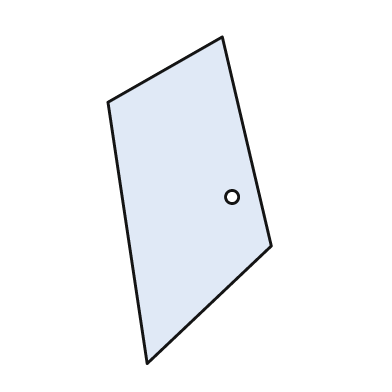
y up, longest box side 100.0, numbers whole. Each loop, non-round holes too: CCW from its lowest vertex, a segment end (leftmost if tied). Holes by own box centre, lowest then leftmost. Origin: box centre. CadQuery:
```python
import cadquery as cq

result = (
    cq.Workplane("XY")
    .moveTo(-13.0, -50.0)
    .lineTo(25.0, -14.0)
    .lineTo(10.0, 50.0)
    .lineTo(-25.0, 30.0)
    .close()
    .moveTo(13.0, 1.0)
    .circle(2.0)
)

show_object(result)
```